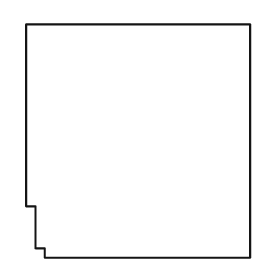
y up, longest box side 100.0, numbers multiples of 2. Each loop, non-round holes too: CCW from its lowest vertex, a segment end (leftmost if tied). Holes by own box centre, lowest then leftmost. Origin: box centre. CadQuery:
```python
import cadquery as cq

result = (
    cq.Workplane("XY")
    .moveTo(-40.0, -50.0)
    .lineTo(48.0, -50.0)
    .lineTo(48.0, 50.0)
    .lineTo(-48.0, 50.0)
    .lineTo(-48.0, -28.0)
    .lineTo(-44.0, -28.0)
    .lineTo(-44.0, -46.0)
    .lineTo(-40.0, -46.0)
    .close()
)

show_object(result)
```